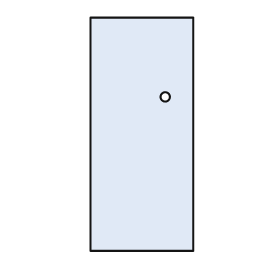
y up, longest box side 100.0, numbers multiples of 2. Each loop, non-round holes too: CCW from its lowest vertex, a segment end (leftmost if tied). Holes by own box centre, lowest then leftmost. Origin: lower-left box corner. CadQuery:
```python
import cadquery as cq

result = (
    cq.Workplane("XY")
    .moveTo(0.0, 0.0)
    .lineTo(44.0, 0.0)
    .lineTo(44.0, 100.0)
    .lineTo(0.0, 100.0)
    .close()
    .moveTo(32.0, 66.0)
    .circle(2.0)
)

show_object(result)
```